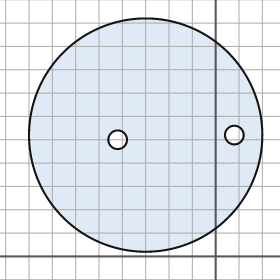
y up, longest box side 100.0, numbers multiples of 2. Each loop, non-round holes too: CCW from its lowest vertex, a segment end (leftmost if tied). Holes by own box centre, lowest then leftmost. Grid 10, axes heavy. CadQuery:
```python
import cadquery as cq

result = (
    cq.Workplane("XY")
    .moveTo(-30.0, 52.0)
    .circle(50.0)
    .moveTo(-42.0, 50.0)
    .circle(4.0)
    .moveTo(8.0, 52.0)
    .circle(4.0)
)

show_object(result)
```